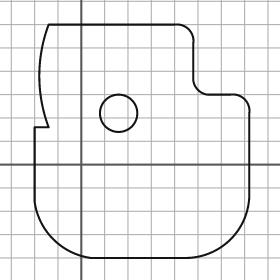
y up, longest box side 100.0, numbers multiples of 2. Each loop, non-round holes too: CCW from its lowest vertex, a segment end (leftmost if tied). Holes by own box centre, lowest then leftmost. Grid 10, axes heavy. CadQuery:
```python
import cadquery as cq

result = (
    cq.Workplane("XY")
    .moveTo(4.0, -40.0)
    .lineTo(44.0, -40.0)
    .threePointArc((64.0, -32.0), (72.0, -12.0))
    .lineTo(72.0, 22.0)
    .threePointArc((70.0, 28.0), (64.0, 30.0))
    .lineTo(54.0, 30.0)
    .threePointArc((50.0, 32.0), (48.0, 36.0))
    .lineTo(48.0, 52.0)
    .threePointArc((46.0, 58.0), (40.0, 60.0))
    .lineTo(-14.0, 60.0)
    .threePointArc((-18.0, 38.0), (-14.0, 16.0))
    .lineTo(-20.0, 16.0)
    .lineTo(-20.0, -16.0)
    .threePointArc((-12.0, -32.0), (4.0, -40.0))
    .close()
    .moveTo(16.0, 22.0)
    .circle(8.0)
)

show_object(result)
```